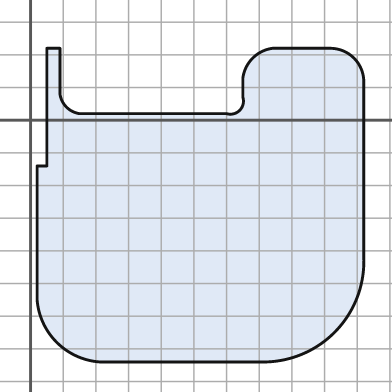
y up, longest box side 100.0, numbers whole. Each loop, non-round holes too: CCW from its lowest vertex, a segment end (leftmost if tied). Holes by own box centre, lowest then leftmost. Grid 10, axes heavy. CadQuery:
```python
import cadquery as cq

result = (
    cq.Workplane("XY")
    .moveTo(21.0, -74.0)
    .lineTo(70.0, -74.0)
    .threePointArc((93.0, -65.0), (102.0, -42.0))
    .lineTo(102.0, 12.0)
    .threePointArc((99.0, 19.0), (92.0, 22.0))
    .lineTo(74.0, 22.0)
    .threePointArc((68.0, 19.0), (65.0, 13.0))
    .lineTo(65.0, 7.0)
    .threePointArc((64.0, 3.0), (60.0, 2.0))
    .lineTo(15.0, 2.0)
    .threePointArc((11.0, 4.0), (9.0, 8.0))
    .lineTo(9.0, 22.0)
    .lineTo(5.0, 22.0)
    .lineTo(5.0, -14.0)
    .lineTo(2.0, -14.0)
    .lineTo(2.0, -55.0)
    .threePointArc((8.0, -68.0), (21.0, -74.0))
    .close()
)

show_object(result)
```